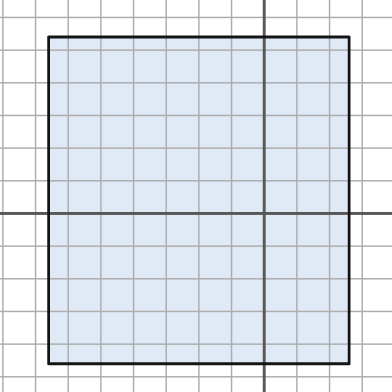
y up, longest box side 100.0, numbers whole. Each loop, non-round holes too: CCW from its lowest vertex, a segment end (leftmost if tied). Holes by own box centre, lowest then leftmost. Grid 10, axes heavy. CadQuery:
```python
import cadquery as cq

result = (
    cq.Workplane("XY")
    .moveTo(-66.0, -46.0)
    .lineTo(26.0, -46.0)
    .lineTo(26.0, 54.0)
    .lineTo(-66.0, 54.0)
    .close()
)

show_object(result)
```